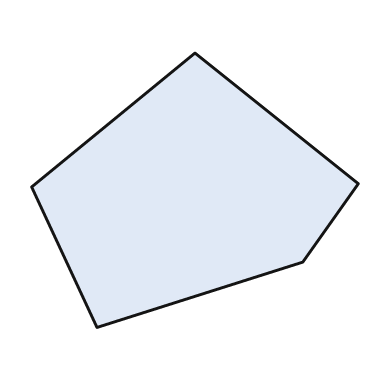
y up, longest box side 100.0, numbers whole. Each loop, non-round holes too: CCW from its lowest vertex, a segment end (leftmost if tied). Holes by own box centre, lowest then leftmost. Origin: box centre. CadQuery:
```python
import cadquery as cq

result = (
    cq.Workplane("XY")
    .moveTo(-30.0, -42.0)
    .lineTo(33.0, -22.0)
    .lineTo(50.0, 2.0)
    .lineTo(0.0, 42.0)
    .lineTo(-50.0, 1.0)
    .close()
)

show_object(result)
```